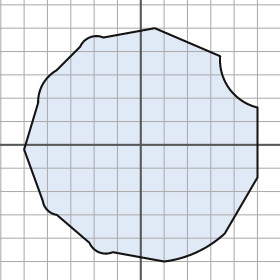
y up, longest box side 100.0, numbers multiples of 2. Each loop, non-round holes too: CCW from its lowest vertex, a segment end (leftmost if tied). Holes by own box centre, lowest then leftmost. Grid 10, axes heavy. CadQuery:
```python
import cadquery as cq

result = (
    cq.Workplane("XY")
    .moveTo(10.0, -50.0)
    .threePointArc((24.0, -46.0), (36.0, -38.0))
    .lineTo(50.0, -14.0)
    .lineTo(50.0, 16.0)
    .threePointArc((38.0, 24.0), (34.0, 38.0))
    .lineTo(6.0, 50.0)
    .lineTo(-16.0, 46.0)
    .threePointArc((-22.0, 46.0), (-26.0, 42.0))
    .lineTo(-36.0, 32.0)
    .threePointArc((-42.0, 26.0), (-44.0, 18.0))
    .lineTo(-50.0, -2.0)
    .lineTo(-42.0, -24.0)
    .threePointArc((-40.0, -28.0), (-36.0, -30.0))
    .lineTo(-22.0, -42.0)
    .threePointArc((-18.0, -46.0), (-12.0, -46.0))
    .close()
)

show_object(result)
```